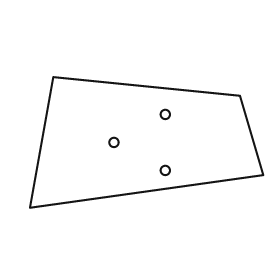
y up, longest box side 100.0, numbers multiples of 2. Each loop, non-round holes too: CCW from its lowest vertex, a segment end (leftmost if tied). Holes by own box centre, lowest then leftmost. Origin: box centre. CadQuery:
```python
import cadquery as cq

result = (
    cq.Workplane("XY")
    .moveTo(-50.0, -28.0)
    .lineTo(50.0, -14.0)
    .lineTo(40.0, 20.0)
    .lineTo(-40.0, 28.0)
    .close()
    .moveTo(8.0, -12.0)
    .circle(2.0)
    .moveTo(-14.0, 0.0)
    .circle(2.0)
    .moveTo(8.0, 12.0)
    .circle(2.0)
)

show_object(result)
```